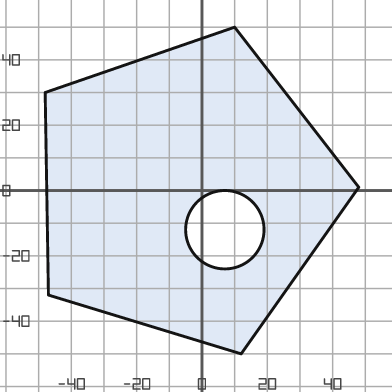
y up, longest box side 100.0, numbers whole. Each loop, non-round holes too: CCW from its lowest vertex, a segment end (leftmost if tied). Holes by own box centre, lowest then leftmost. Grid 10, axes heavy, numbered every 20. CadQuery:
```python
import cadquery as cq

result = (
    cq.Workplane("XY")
    .moveTo(12.0, -50.0)
    .lineTo(48.0, 1.0)
    .lineTo(10.0, 50.0)
    .lineTo(-48.0, 30.0)
    .lineTo(-47.0, -32.0)
    .close()
    .moveTo(7.0, -12.0)
    .circle(12.0)
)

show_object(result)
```